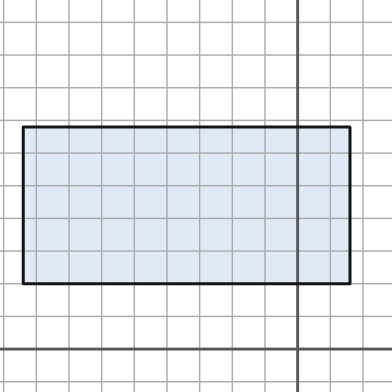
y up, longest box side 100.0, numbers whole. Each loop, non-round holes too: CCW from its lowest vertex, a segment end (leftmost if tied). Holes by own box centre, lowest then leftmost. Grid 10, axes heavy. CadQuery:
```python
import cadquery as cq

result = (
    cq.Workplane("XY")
    .moveTo(-84.0, 20.0)
    .lineTo(16.0, 20.0)
    .lineTo(16.0, 68.0)
    .lineTo(-84.0, 68.0)
    .close()
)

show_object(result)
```